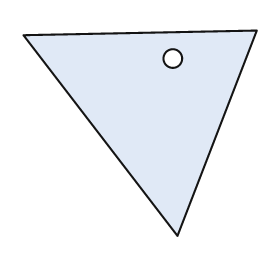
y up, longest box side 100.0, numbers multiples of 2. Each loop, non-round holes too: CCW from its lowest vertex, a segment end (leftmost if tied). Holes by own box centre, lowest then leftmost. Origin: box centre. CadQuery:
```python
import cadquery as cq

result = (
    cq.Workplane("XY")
    .moveTo(16.0, -44.0)
    .lineTo(50.0, 44.0)
    .lineTo(-50.0, 42.0)
    .close()
    .moveTo(14.0, 32.0)
    .circle(4.0)
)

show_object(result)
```